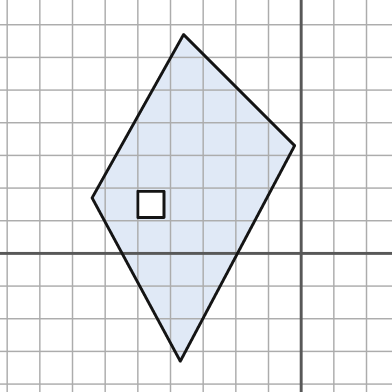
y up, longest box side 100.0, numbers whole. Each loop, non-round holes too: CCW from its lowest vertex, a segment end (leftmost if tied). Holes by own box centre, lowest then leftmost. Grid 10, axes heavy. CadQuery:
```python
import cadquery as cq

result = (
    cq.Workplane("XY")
    .moveTo(-37.0, -33.0)
    .lineTo(-2.0, 33.0)
    .lineTo(-36.0, 67.0)
    .lineTo(-64.0, 17.0)
    .close()
    .moveTo(-50.0, 11.0)
    .lineTo(-42.0, 11.0)
    .lineTo(-42.0, 19.0)
    .lineTo(-50.0, 19.0)
    .close()
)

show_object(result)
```